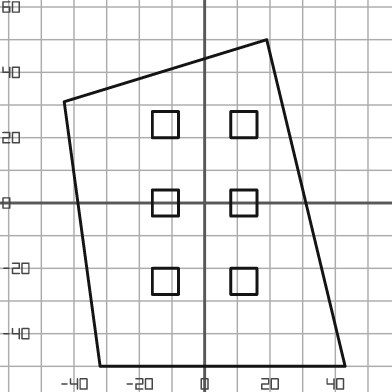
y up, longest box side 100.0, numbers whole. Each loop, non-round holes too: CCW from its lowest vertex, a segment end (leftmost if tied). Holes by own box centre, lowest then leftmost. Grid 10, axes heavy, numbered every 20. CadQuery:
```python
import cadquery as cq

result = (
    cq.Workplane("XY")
    .moveTo(-32.0, -50.0)
    .lineTo(43.0, -50.0)
    .lineTo(19.0, 50.0)
    .lineTo(-43.0, 31.0)
    .close()
    .moveTo(-16.0, -28.0)
    .lineTo(-8.0, -28.0)
    .lineTo(-8.0, -20.0)
    .lineTo(-16.0, -20.0)
    .close()
    .moveTo(8.0, -28.0)
    .lineTo(16.0, -28.0)
    .lineTo(16.0, -20.0)
    .lineTo(8.0, -20.0)
    .close()
    .moveTo(-16.0, -4.0)
    .lineTo(-8.0, -4.0)
    .lineTo(-8.0, 4.0)
    .lineTo(-16.0, 4.0)
    .close()
    .moveTo(8.0, -4.0)
    .lineTo(16.0, -4.0)
    .lineTo(16.0, 4.0)
    .lineTo(8.0, 4.0)
    .close()
    .moveTo(-16.0, 20.0)
    .lineTo(-8.0, 20.0)
    .lineTo(-8.0, 28.0)
    .lineTo(-16.0, 28.0)
    .close()
    .moveTo(8.0, 20.0)
    .lineTo(16.0, 20.0)
    .lineTo(16.0, 28.0)
    .lineTo(8.0, 28.0)
    .close()
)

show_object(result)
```